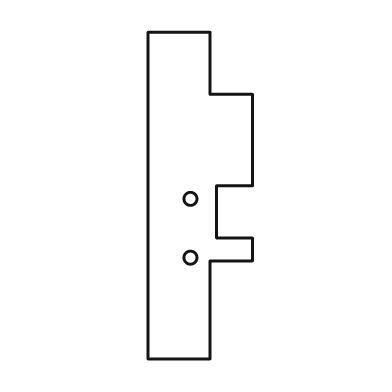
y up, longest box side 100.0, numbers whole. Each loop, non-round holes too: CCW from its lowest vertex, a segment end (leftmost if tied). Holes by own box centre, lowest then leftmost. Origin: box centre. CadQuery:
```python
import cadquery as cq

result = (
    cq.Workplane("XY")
    .moveTo(-16.0, -50.0)
    .lineTo(3.0, -50.0)
    .lineTo(3.0, -20.0)
    .lineTo(16.0, -20.0)
    .lineTo(16.0, -13.0)
    .lineTo(5.0, -13.0)
    .lineTo(5.0, 3.0)
    .lineTo(16.0, 3.0)
    .lineTo(16.0, 31.0)
    .lineTo(3.0, 31.0)
    .lineTo(3.0, 50.0)
    .lineTo(-16.0, 50.0)
    .close()
    .moveTo(-3.0, -19.0)
    .circle(2.0)
    .moveTo(-3.0, -1.0)
    .circle(2.0)
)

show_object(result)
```